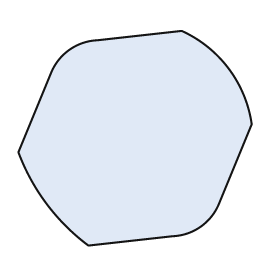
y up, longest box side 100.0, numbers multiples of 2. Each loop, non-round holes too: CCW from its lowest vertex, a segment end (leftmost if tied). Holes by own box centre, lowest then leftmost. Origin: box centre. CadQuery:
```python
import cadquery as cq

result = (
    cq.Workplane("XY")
    .moveTo(-20.0, -46.0)
    .lineTo(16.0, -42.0)
    .threePointArc((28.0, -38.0), (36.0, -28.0))
    .lineTo(50.0, 6.0)
    .threePointArc((40.0, 30.0), (20.0, 46.0))
    .lineTo(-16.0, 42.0)
    .threePointArc((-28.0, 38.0), (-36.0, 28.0))
    .lineTo(-50.0, -6.0)
    .threePointArc((-38.0, -28.0), (-20.0, -46.0))
    .close()
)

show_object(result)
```